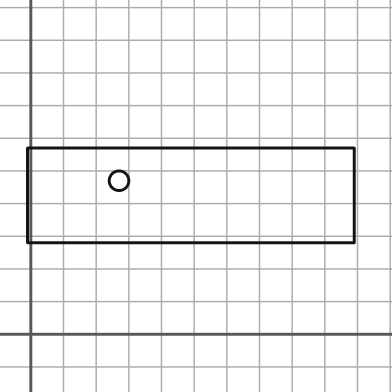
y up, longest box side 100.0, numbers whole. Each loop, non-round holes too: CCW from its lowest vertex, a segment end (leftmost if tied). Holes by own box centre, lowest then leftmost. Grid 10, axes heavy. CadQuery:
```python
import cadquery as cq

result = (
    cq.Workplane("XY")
    .moveTo(-1.0, 28.0)
    .lineTo(99.0, 28.0)
    .lineTo(99.0, 57.0)
    .lineTo(-1.0, 57.0)
    .close()
    .moveTo(27.0, 47.0)
    .circle(3.0)
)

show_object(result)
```